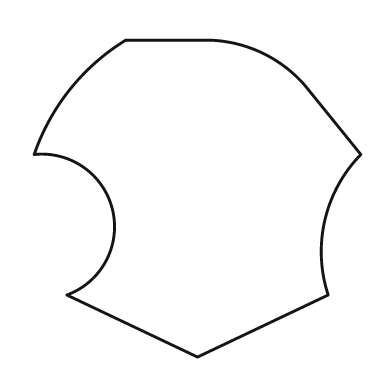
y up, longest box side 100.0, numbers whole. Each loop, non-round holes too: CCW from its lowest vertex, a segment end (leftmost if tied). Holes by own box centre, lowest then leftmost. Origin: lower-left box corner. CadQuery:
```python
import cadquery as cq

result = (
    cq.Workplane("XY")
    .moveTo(50.0, 0.0)
    .lineTo(90.0, 19.0)
    .threePointArc((89.0, 42.0), (100.0, 62.0))
    .lineTo(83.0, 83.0)
    .threePointArc((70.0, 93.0), (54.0, 97.0))
    .lineTo(28.0, 97.0)
    .threePointArc((11.0, 82.0), (0.0, 62.0))
    .threePointArc((24.0, 45.0), (10.0, 19.0))
    .close()
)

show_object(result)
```